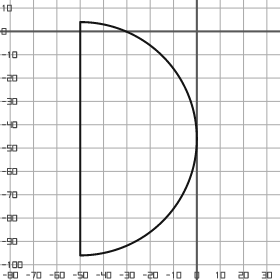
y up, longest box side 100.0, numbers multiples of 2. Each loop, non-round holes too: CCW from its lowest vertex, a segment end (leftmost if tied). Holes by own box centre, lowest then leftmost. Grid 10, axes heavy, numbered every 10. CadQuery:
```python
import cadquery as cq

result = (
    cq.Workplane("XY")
    .moveTo(-50.0, -96.0)
    .threePointArc((0.0, -46.0), (-50.0, 4.0))
    .close()
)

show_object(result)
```